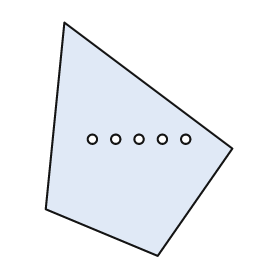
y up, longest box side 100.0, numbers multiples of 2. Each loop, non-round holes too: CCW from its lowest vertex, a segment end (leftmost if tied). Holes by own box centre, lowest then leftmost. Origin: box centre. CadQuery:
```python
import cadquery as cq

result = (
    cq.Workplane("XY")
    .moveTo(8.0, -50.0)
    .lineTo(40.0, -4.0)
    .lineTo(-32.0, 50.0)
    .lineTo(-40.0, -30.0)
    .close()
    .moveTo(-20.0, 0.0)
    .circle(2.0)
    .moveTo(-10.0, 0.0)
    .circle(2.0)
    .moveTo(0.0, 0.0)
    .circle(2.0)
    .moveTo(10.0, 0.0)
    .circle(2.0)
    .moveTo(20.0, 0.0)
    .circle(2.0)
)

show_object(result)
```